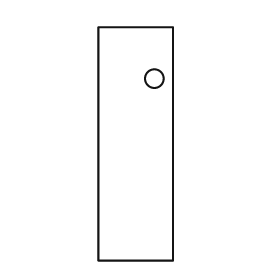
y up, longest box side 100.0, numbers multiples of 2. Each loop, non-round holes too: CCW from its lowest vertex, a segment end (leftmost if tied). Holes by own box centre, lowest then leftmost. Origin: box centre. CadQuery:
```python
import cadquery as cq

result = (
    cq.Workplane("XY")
    .moveTo(-16.0, -50.0)
    .lineTo(16.0, -50.0)
    .lineTo(16.0, 50.0)
    .lineTo(-16.0, 50.0)
    .close()
    .moveTo(8.0, 28.0)
    .circle(4.0)
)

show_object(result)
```